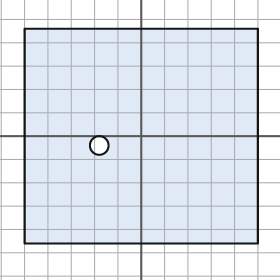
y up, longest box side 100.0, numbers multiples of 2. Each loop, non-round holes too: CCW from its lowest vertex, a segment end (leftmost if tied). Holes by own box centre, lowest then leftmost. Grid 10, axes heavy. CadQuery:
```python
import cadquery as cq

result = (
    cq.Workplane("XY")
    .moveTo(-50.0, -46.0)
    .lineTo(50.0, -46.0)
    .lineTo(50.0, 46.0)
    .lineTo(-50.0, 46.0)
    .close()
    .moveTo(-18.0, -4.0)
    .circle(4.0)
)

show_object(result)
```